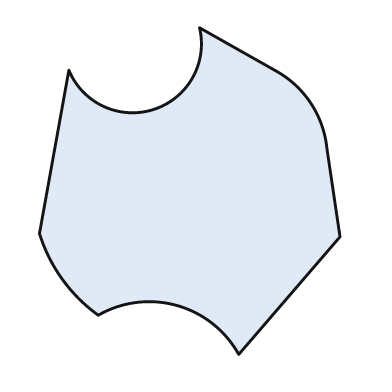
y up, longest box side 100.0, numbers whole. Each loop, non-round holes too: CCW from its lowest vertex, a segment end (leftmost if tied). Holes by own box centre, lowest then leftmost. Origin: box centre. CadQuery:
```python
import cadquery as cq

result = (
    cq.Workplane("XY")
    .moveTo(15.0, -50.0)
    .lineTo(46.0, -14.0)
    .lineTo(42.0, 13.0)
    .threePointArc((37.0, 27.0), (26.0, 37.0))
    .lineTo(3.0, 50.0)
    .threePointArc((-11.0, 25.0), (-37.0, 37.0))
    .lineTo(-46.0, -13.0)
    .threePointArc((-39.0, -27.0), (-28.0, -38.0))
    .threePointArc((-4.0, -35.0), (15.0, -50.0))
    .close()
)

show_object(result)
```